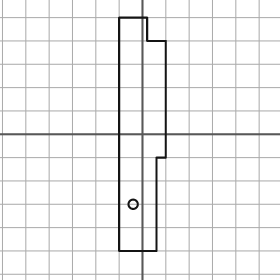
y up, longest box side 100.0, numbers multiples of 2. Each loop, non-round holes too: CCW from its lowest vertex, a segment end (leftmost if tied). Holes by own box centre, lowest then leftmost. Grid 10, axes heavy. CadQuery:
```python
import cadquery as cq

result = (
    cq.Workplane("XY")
    .moveTo(-10.0, -50.0)
    .lineTo(6.0, -50.0)
    .lineTo(6.0, -10.0)
    .lineTo(10.0, -10.0)
    .lineTo(10.0, 40.0)
    .lineTo(2.0, 40.0)
    .lineTo(2.0, 50.0)
    .lineTo(-10.0, 50.0)
    .close()
    .moveTo(-4.0, -30.0)
    .circle(2.0)
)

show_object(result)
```